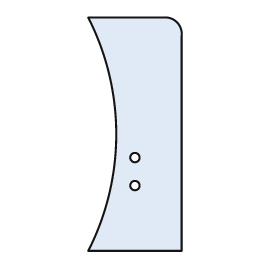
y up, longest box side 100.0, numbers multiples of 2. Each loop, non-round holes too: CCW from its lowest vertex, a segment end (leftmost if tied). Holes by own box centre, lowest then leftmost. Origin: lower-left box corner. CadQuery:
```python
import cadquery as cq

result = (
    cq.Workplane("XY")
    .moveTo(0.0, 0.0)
    .lineTo(40.0, 0.0)
    .lineTo(40.0, 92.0)
    .threePointArc((38.0, 98.0), (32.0, 100.0))
    .lineTo(0.0, 100.0)
    .threePointArc((12.0, 50.0), (0.0, 0.0))
    .close()
    .moveTo(20.0, 28.0)
    .circle(2.0)
    .moveTo(20.0, 40.0)
    .circle(2.0)
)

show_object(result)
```